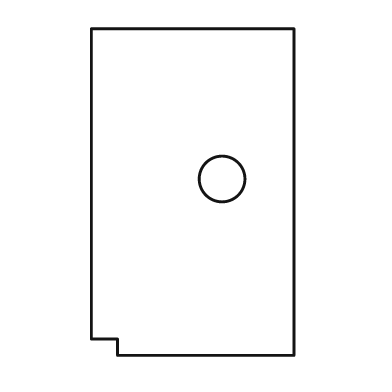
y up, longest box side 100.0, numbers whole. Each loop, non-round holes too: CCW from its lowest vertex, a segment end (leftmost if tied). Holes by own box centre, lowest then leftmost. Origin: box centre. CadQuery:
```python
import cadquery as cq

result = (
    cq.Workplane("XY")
    .moveTo(-23.0, -50.0)
    .lineTo(31.0, -50.0)
    .lineTo(31.0, 50.0)
    .lineTo(-31.0, 50.0)
    .lineTo(-31.0, -45.0)
    .lineTo(-23.0, -45.0)
    .close()
    .moveTo(9.0, 4.0)
    .circle(7.0)
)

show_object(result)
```